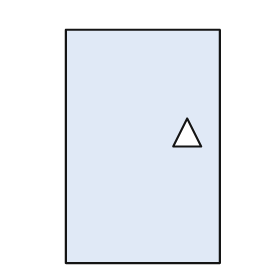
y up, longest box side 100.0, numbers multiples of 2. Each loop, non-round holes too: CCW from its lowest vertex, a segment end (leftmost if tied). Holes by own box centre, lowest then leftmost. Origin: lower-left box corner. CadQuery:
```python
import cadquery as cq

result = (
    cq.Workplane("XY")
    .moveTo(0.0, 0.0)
    .lineTo(66.0, 0.0)
    .lineTo(66.0, 100.0)
    .lineTo(0.0, 100.0)
    .close()
    .moveTo(46.0, 50.0)
    .lineTo(58.0, 50.0)
    .lineTo(52.0, 62.0)
    .close()
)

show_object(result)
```